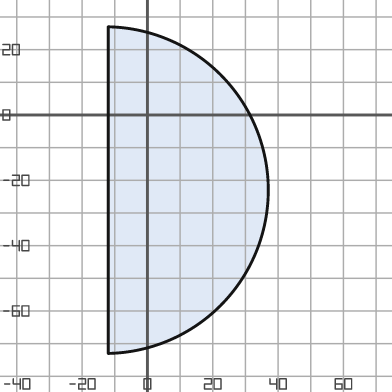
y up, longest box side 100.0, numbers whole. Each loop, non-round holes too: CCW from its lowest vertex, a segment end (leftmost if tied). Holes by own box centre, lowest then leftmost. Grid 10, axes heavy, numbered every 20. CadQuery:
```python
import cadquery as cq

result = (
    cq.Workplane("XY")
    .moveTo(-12.0, -73.0)
    .threePointArc((37.0, -23.0), (-12.0, 27.0))
    .close()
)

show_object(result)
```